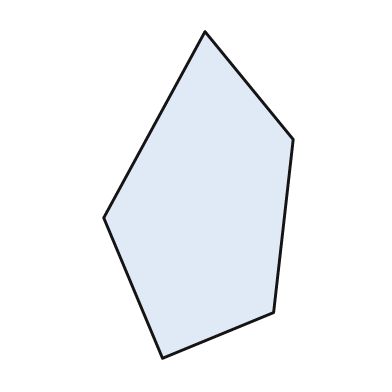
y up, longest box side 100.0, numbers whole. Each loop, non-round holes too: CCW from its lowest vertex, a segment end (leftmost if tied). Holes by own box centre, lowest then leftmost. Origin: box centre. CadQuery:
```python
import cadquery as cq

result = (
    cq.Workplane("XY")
    .moveTo(-11.0, -50.0)
    .lineTo(23.0, -36.0)
    .lineTo(29.0, 17.0)
    .lineTo(2.0, 50.0)
    .lineTo(-29.0, -7.0)
    .close()
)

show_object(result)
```